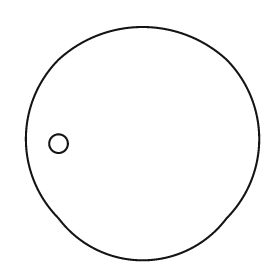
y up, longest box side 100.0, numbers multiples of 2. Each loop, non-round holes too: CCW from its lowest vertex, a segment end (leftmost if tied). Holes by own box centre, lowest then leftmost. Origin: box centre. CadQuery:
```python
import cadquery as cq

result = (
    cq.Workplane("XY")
    .moveTo(-36.0, -32.0)
    .threePointArc((0.0, -50.0), (36.0, -32.0))
    .threePointArc((50.0, 2.0), (36.0, 36.0))
    .threePointArc((0.0, 50.0), (-36.0, 36.0))
    .threePointArc((-50.0, 2.0), (-36.0, -32.0))
    .close()
    .moveTo(-36.0, 0.0)
    .circle(4.0)
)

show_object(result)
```